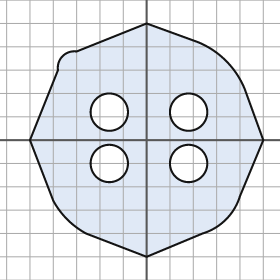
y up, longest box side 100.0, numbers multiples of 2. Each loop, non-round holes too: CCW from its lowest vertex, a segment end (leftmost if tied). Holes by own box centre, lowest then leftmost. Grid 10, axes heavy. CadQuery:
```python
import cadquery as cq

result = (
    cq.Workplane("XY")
    .moveTo(0.0, -50.0)
    .lineTo(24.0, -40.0)
    .threePointArc((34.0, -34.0), (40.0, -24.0))
    .lineTo(50.0, 0.0)
    .lineTo(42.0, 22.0)
    .threePointArc((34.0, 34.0), (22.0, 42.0))
    .lineTo(0.0, 50.0)
    .lineTo(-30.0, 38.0)
    .threePointArc((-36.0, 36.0), (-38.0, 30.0))
    .lineTo(-50.0, 0.0)
    .lineTo(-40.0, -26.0)
    .threePointArc((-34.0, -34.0), (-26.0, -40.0))
    .close()
    .moveTo(-16.0, -10.0)
    .circle(8.0)
    .moveTo(18.0, -10.0)
    .circle(8.0)
    .moveTo(-16.0, 12.0)
    .circle(8.0)
    .moveTo(18.0, 12.0)
    .circle(8.0)
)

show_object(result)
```